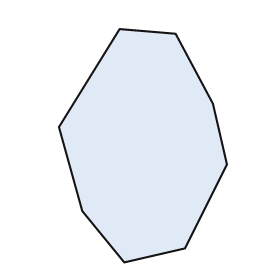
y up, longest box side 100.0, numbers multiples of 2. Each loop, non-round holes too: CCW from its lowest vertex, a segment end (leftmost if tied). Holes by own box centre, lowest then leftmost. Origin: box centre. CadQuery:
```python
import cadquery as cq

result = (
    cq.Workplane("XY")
    .moveTo(-8.0, -50.0)
    .lineTo(18.0, -44.0)
    .lineTo(36.0, -8.0)
    .lineTo(30.0, 18.0)
    .lineTo(14.0, 48.0)
    .lineTo(-10.0, 50.0)
    .lineTo(-36.0, 8.0)
    .lineTo(-26.0, -28.0)
    .close()
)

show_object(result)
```